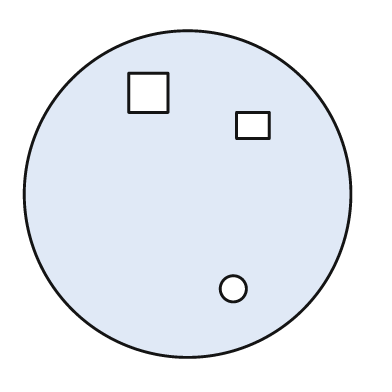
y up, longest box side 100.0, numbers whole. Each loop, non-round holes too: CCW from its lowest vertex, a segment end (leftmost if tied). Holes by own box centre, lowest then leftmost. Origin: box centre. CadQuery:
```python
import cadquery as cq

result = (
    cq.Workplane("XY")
    .moveTo(0.0, 0.0)
    .circle(50.0)
    .moveTo(14.0, -29.0)
    .circle(4.0)
    .moveTo(15.0, 17.0)
    .lineTo(25.0, 17.0)
    .lineTo(25.0, 25.0)
    .lineTo(15.0, 25.0)
    .close()
    .moveTo(-18.0, 25.0)
    .lineTo(-6.0, 25.0)
    .lineTo(-6.0, 37.0)
    .lineTo(-18.0, 37.0)
    .close()
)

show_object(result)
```